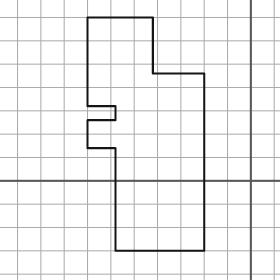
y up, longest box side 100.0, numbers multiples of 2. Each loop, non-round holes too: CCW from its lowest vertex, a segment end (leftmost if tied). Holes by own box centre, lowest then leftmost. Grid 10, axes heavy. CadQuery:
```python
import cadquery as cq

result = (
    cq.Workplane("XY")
    .moveTo(-58.0, -30.0)
    .lineTo(-20.0, -30.0)
    .lineTo(-20.0, 46.0)
    .lineTo(-42.0, 46.0)
    .lineTo(-42.0, 70.0)
    .lineTo(-70.0, 70.0)
    .lineTo(-70.0, 32.0)
    .lineTo(-58.0, 32.0)
    .lineTo(-58.0, 26.0)
    .lineTo(-70.0, 26.0)
    .lineTo(-70.0, 14.0)
    .lineTo(-58.0, 14.0)
    .close()
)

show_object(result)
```